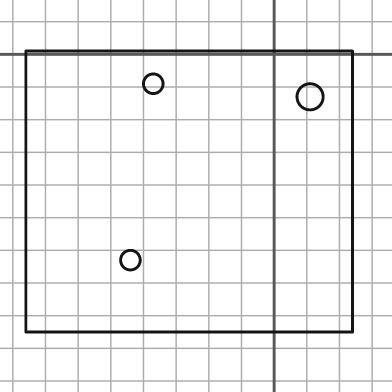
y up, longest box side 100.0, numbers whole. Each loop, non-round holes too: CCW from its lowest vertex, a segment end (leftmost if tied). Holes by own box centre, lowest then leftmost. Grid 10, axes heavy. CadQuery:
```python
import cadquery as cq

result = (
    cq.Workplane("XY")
    .moveTo(-76.0, -85.0)
    .lineTo(24.0, -85.0)
    .lineTo(24.0, 1.0)
    .lineTo(-76.0, 1.0)
    .close()
    .moveTo(-44.0, -63.0)
    .circle(3.0)
    .moveTo(11.0, -13.0)
    .circle(4.0)
    .moveTo(-37.0, -9.0)
    .circle(3.0)
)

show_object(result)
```